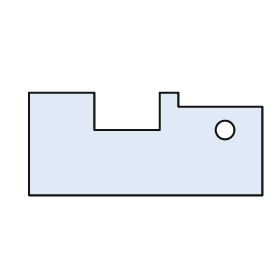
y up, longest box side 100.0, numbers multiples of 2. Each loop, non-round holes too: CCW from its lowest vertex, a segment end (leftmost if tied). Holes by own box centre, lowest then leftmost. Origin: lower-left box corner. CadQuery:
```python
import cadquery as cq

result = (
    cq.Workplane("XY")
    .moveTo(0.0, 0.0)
    .lineTo(100.0, 0.0)
    .lineTo(100.0, 38.0)
    .lineTo(64.0, 38.0)
    .lineTo(64.0, 44.0)
    .lineTo(56.0, 44.0)
    .lineTo(56.0, 28.0)
    .lineTo(28.0, 28.0)
    .lineTo(28.0, 44.0)
    .lineTo(0.0, 44.0)
    .close()
    .moveTo(84.0, 28.0)
    .circle(4.0)
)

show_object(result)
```